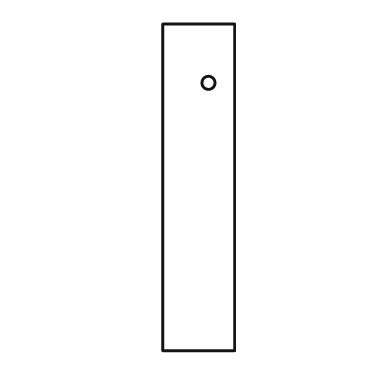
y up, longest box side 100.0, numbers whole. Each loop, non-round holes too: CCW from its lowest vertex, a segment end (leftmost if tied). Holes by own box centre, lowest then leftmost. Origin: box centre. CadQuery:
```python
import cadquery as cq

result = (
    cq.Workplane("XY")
    .moveTo(-11.0, -50.0)
    .lineTo(11.0, -50.0)
    .lineTo(11.0, 50.0)
    .lineTo(-11.0, 50.0)
    .close()
    .moveTo(3.0, 32.0)
    .circle(2.0)
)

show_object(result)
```